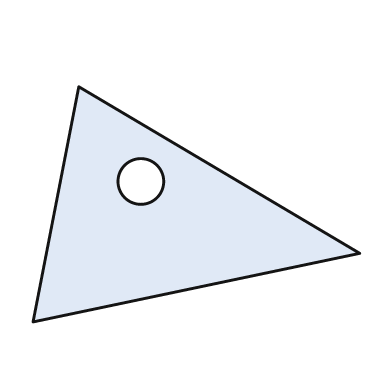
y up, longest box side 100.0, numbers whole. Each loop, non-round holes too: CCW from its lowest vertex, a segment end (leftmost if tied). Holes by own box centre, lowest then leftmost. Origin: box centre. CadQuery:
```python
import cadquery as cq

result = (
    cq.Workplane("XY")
    .moveTo(-50.0, -36.0)
    .lineTo(50.0, -15.0)
    .lineTo(-36.0, 36.0)
    .close()
    .moveTo(-17.0, 7.0)
    .circle(7.0)
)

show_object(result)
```